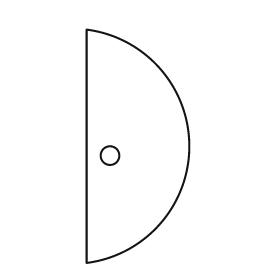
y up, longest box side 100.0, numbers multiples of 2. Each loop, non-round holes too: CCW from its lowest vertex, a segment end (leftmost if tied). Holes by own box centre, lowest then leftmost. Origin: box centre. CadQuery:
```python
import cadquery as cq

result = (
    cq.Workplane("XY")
    .moveTo(-22.0, -50.0)
    .threePointArc((22.0, 0.0), (-22.0, 50.0))
    .close()
    .moveTo(-12.0, -4.0)
    .circle(4.0)
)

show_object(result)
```